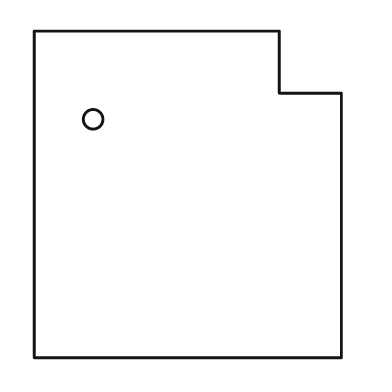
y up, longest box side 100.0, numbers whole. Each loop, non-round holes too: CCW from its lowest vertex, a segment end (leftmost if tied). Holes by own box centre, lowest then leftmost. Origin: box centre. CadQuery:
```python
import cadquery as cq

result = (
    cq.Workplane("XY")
    .moveTo(-47.0, -50.0)
    .lineTo(47.0, -50.0)
    .lineTo(47.0, 31.0)
    .lineTo(28.0, 31.0)
    .lineTo(28.0, 50.0)
    .lineTo(-47.0, 50.0)
    .close()
    .moveTo(-29.0, 23.0)
    .circle(3.0)
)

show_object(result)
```